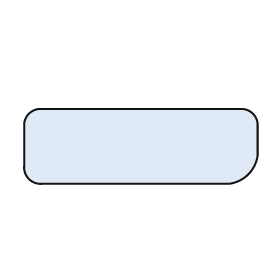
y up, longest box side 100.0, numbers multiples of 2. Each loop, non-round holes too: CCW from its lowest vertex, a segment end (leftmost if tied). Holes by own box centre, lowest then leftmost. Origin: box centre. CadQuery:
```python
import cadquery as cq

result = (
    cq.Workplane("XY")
    .moveTo(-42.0, -16.0)
    .lineTo(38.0, -16.0)
    .threePointArc((46.0, -12.0), (50.0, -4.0))
    .lineTo(50.0, 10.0)
    .threePointArc((48.0, 14.0), (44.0, 16.0))
    .lineTo(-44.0, 16.0)
    .threePointArc((-48.0, 14.0), (-50.0, 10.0))
    .lineTo(-50.0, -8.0)
    .threePointArc((-48.0, -14.0), (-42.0, -16.0))
    .close()
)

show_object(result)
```